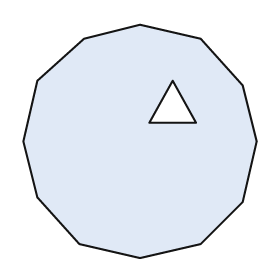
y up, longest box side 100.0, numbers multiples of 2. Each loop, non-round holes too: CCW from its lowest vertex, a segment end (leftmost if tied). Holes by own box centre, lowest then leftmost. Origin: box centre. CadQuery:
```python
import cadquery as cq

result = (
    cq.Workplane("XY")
    .moveTo(0.0, -50.0)
    .lineTo(26.0, -44.0)
    .lineTo(44.0, -26.0)
    .lineTo(50.0, 0.0)
    .lineTo(44.0, 24.0)
    .lineTo(26.0, 44.0)
    .lineTo(0.0, 50.0)
    .lineTo(-24.0, 44.0)
    .lineTo(-44.0, 26.0)
    .lineTo(-50.0, 0.0)
    .lineTo(-44.0, -24.0)
    .lineTo(-26.0, -44.0)
    .close()
    .moveTo(4.0, 8.0)
    .lineTo(24.0, 8.0)
    .lineTo(14.0, 26.0)
    .close()
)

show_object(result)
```